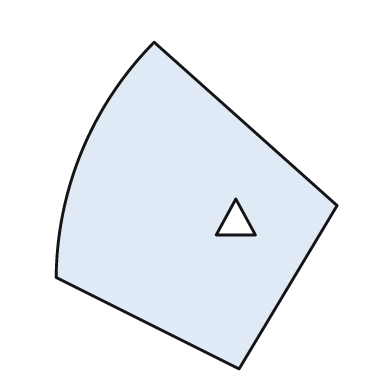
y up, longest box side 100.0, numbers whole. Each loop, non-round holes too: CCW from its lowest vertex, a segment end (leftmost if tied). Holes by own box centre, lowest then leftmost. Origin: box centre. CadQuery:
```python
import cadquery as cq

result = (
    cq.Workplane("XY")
    .moveTo(13.0, -50.0)
    .lineTo(43.0, 0.0)
    .lineTo(-13.0, 50.0)
    .threePointArc((-35.0, 17.0), (-43.0, -22.0))
    .close()
    .moveTo(6.0, -9.0)
    .lineTo(18.0, -9.0)
    .lineTo(12.0, 2.0)
    .close()
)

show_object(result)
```